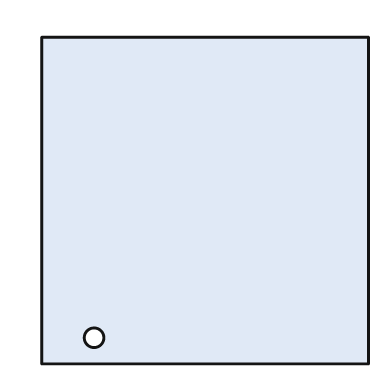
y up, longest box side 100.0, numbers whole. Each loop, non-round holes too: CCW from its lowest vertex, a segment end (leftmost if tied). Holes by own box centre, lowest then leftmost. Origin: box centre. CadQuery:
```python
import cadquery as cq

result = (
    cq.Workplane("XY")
    .moveTo(-50.0, -50.0)
    .lineTo(50.0, -50.0)
    .lineTo(50.0, 50.0)
    .lineTo(-50.0, 50.0)
    .close()
    .moveTo(-34.0, -42.0)
    .circle(3.0)
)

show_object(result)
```